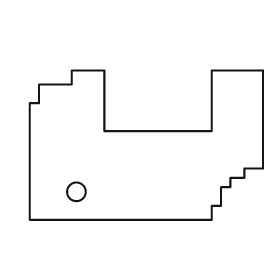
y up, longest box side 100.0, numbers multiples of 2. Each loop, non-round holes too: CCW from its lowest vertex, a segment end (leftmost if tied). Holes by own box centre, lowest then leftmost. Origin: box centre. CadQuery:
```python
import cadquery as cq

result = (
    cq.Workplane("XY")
    .moveTo(-50.0, -32.0)
    .lineTo(28.0, -32.0)
    .lineTo(28.0, -26.0)
    .lineTo(32.0, -26.0)
    .lineTo(32.0, -18.0)
    .lineTo(36.0, -18.0)
    .lineTo(36.0, -14.0)
    .lineTo(42.0, -14.0)
    .lineTo(42.0, -10.0)
    .lineTo(50.0, -10.0)
    .lineTo(50.0, 32.0)
    .lineTo(28.0, 32.0)
    .lineTo(28.0, 6.0)
    .lineTo(-18.0, 6.0)
    .lineTo(-18.0, 32.0)
    .lineTo(-32.0, 32.0)
    .lineTo(-32.0, 26.0)
    .lineTo(-46.0, 26.0)
    .lineTo(-46.0, 18.0)
    .lineTo(-50.0, 18.0)
    .close()
    .moveTo(-30.0, -20.0)
    .circle(4.0)
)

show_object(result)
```